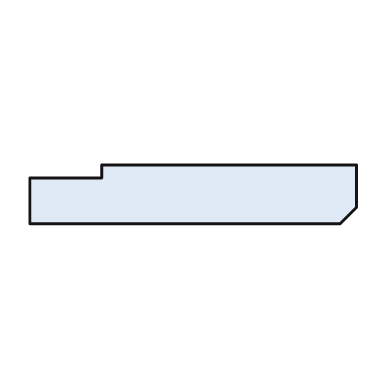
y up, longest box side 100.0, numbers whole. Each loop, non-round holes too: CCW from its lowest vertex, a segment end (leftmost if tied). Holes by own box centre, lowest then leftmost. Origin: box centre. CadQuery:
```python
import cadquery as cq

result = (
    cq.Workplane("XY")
    .moveTo(-50.0, -9.0)
    .lineTo(45.0, -9.0)
    .lineTo(50.0, -4.0)
    .lineTo(50.0, 9.0)
    .lineTo(-28.0, 9.0)
    .lineTo(-28.0, 5.0)
    .lineTo(-50.0, 5.0)
    .close()
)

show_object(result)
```